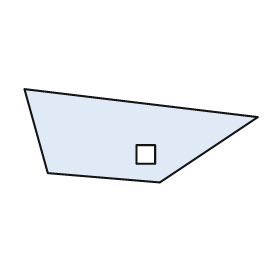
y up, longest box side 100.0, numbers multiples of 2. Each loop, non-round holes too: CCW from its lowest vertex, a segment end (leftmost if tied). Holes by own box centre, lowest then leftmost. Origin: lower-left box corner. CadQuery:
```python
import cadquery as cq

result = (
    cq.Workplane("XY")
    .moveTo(58.0, 0.0)
    .lineTo(100.0, 28.0)
    .lineTo(0.0, 40.0)
    .lineTo(10.0, 4.0)
    .close()
    .moveTo(48.0, 8.0)
    .lineTo(56.0, 8.0)
    .lineTo(56.0, 16.0)
    .lineTo(48.0, 16.0)
    .close()
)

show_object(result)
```